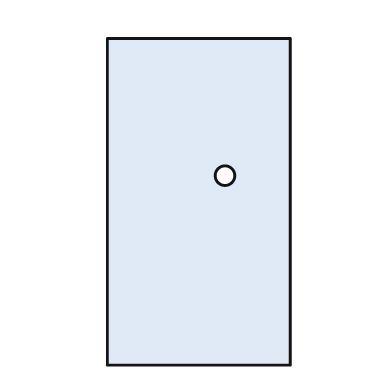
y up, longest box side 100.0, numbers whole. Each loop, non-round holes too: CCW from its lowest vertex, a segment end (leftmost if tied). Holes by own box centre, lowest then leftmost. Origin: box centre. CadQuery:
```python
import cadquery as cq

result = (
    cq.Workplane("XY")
    .moveTo(-28.0, -50.0)
    .lineTo(28.0, -50.0)
    .lineTo(28.0, 50.0)
    .lineTo(-28.0, 50.0)
    .close()
    .moveTo(8.0, 8.0)
    .circle(3.0)
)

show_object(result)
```